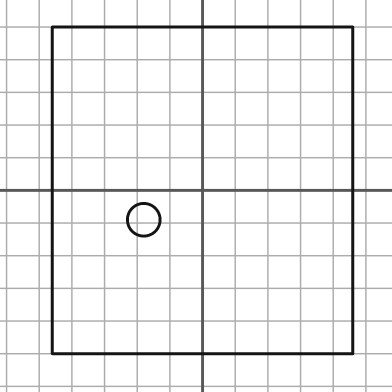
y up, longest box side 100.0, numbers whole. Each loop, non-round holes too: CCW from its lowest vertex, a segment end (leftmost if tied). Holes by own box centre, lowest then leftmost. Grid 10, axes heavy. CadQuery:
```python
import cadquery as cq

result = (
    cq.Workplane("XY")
    .moveTo(-46.0, -50.0)
    .lineTo(46.0, -50.0)
    .lineTo(46.0, 50.0)
    .lineTo(-46.0, 50.0)
    .close()
    .moveTo(-18.0, -9.0)
    .circle(5.0)
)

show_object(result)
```